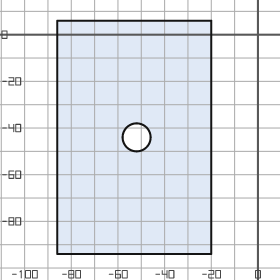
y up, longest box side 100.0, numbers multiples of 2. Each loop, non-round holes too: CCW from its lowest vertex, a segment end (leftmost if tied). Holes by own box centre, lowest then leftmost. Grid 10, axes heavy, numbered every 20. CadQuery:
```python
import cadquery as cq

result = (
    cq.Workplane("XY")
    .moveTo(-86.0, -94.0)
    .lineTo(-20.0, -94.0)
    .lineTo(-20.0, 6.0)
    .lineTo(-86.0, 6.0)
    .close()
    .moveTo(-52.0, -44.0)
    .circle(6.0)
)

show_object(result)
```